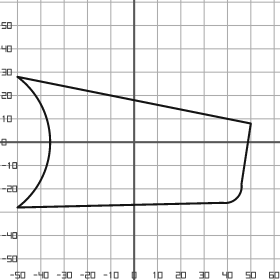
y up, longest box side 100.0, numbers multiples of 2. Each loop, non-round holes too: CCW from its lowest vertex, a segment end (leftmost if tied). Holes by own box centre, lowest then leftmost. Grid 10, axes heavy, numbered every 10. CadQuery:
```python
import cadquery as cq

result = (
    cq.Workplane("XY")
    .moveTo(-50.0, -28.0)
    .lineTo(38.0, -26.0)
    .threePointArc((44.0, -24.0), (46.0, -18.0))
    .lineTo(50.0, 8.0)
    .lineTo(-50.0, 28.0)
    .threePointArc((-36.0, 0.0), (-50.0, -28.0))
    .close()
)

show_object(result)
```